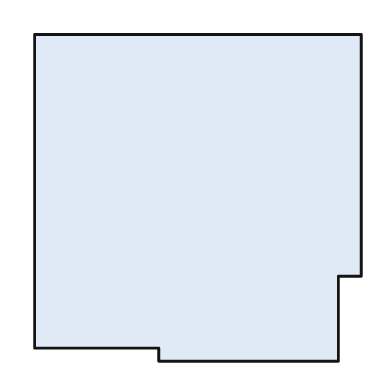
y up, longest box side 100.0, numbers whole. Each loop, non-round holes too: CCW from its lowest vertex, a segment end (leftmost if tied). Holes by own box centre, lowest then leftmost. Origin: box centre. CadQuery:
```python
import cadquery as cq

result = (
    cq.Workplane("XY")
    .moveTo(-12.0, -50.0)
    .lineTo(43.0, -50.0)
    .lineTo(43.0, -24.0)
    .lineTo(50.0, -24.0)
    .lineTo(50.0, 50.0)
    .lineTo(-50.0, 50.0)
    .lineTo(-50.0, -46.0)
    .lineTo(-12.0, -46.0)
    .close()
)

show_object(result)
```